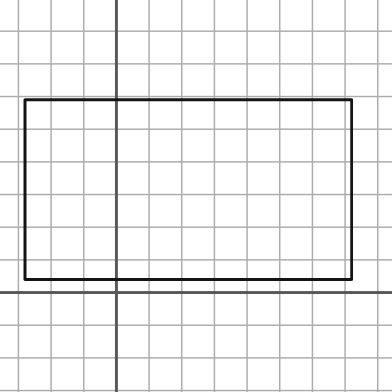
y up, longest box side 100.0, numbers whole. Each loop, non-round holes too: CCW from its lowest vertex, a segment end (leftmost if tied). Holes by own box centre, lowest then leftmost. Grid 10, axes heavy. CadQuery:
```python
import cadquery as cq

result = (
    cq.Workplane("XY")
    .moveTo(-28.0, 4.0)
    .lineTo(72.0, 4.0)
    .lineTo(72.0, 59.0)
    .lineTo(-28.0, 59.0)
    .close()
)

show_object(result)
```